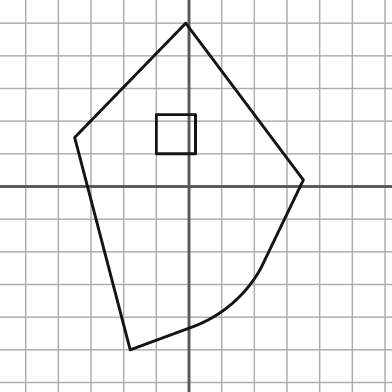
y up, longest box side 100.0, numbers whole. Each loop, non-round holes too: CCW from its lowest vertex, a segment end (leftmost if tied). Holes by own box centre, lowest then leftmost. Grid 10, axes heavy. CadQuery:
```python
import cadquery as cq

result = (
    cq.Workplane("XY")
    .moveTo(-18.0, -50.0)
    .lineTo(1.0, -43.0)
    .threePointArc((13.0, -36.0), (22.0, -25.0))
    .lineTo(35.0, 2.0)
    .lineTo(-1.0, 50.0)
    .lineTo(-35.0, 15.0)
    .close()
    .moveTo(-10.0, 10.0)
    .lineTo(2.0, 10.0)
    .lineTo(2.0, 22.0)
    .lineTo(-10.0, 22.0)
    .close()
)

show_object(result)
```